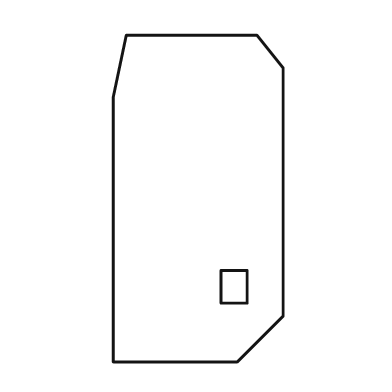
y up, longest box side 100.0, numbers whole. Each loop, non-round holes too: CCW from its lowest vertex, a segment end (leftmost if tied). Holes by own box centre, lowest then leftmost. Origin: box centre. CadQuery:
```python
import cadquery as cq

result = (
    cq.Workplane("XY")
    .moveTo(-26.0, -50.0)
    .lineTo(12.0, -50.0)
    .lineTo(26.0, -36.0)
    .lineTo(26.0, 40.0)
    .lineTo(18.0, 50.0)
    .lineTo(-22.0, 50.0)
    .lineTo(-26.0, 31.0)
    .close()
    .moveTo(7.0, -32.0)
    .lineTo(15.0, -32.0)
    .lineTo(15.0, -22.0)
    .lineTo(7.0, -22.0)
    .close()
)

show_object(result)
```